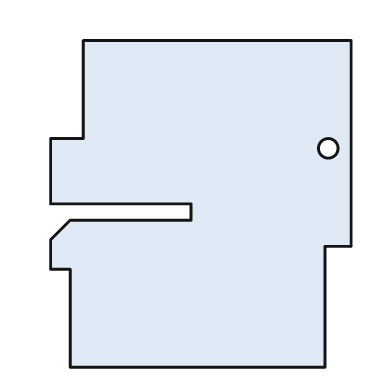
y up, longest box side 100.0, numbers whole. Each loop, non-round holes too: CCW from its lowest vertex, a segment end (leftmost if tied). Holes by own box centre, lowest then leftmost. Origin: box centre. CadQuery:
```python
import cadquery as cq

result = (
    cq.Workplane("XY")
    .moveTo(-40.0, -50.0)
    .lineTo(38.0, -50.0)
    .lineTo(38.0, -13.0)
    .lineTo(46.0, -13.0)
    .lineTo(46.0, 50.0)
    .lineTo(-36.0, 50.0)
    .lineTo(-36.0, 20.0)
    .lineTo(-46.0, 20.0)
    .lineTo(-46.0, 0.0)
    .lineTo(-3.0, 0.0)
    .lineTo(-3.0, -5.0)
    .lineTo(-40.0, -5.0)
    .lineTo(-46.0, -11.0)
    .lineTo(-46.0, -20.0)
    .lineTo(-40.0, -20.0)
    .close()
    .moveTo(39.0, 17.0)
    .circle(3.0)
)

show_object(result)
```